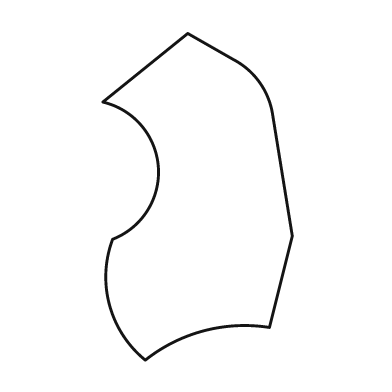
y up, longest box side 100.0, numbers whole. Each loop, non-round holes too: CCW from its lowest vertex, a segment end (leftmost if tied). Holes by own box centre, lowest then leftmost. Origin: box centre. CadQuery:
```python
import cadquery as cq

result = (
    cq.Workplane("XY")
    .moveTo(-16.0, -50.0)
    .threePointArc((2.0, -41.0), (22.0, -40.0))
    .lineTo(29.0, -12.0)
    .lineTo(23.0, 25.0)
    .threePointArc((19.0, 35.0), (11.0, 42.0))
    .lineTo(-3.0, 50.0)
    .lineTo(-29.0, 29.0)
    .threePointArc((-12.0, 9.0), (-26.0, -13.0))
    .threePointArc((-27.0, -33.0), (-16.0, -50.0))
    .close()
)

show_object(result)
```